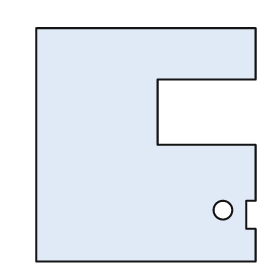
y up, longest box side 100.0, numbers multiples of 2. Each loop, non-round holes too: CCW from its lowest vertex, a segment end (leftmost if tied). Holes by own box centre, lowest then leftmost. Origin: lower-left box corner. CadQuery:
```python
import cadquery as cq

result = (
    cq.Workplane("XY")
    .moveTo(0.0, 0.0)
    .lineTo(94.0, 0.0)
    .lineTo(94.0, 14.0)
    .lineTo(90.0, 14.0)
    .lineTo(90.0, 26.0)
    .lineTo(94.0, 26.0)
    .lineTo(94.0, 50.0)
    .lineTo(52.0, 50.0)
    .lineTo(52.0, 78.0)
    .lineTo(94.0, 78.0)
    .lineTo(94.0, 100.0)
    .lineTo(0.0, 100.0)
    .close()
    .moveTo(80.0, 22.0)
    .circle(4.0)
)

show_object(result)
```